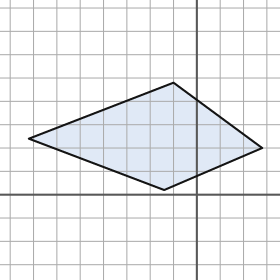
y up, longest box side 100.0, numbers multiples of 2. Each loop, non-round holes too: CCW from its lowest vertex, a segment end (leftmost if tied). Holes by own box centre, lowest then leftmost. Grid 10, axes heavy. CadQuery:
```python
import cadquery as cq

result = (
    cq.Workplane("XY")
    .moveTo(-14.0, 2.0)
    .lineTo(28.0, 20.0)
    .lineTo(-10.0, 48.0)
    .lineTo(-72.0, 24.0)
    .close()
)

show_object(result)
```